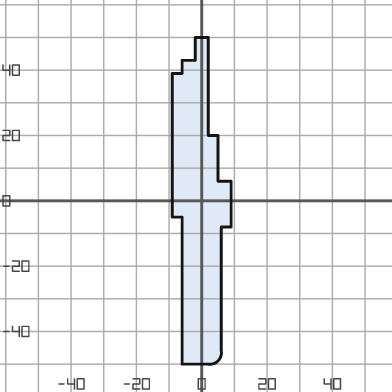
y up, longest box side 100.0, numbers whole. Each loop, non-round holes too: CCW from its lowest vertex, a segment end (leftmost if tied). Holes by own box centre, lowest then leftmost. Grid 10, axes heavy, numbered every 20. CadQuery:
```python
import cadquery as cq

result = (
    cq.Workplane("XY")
    .moveTo(-6.0, -50.0)
    .lineTo(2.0, -50.0)
    .threePointArc((5.0, -49.0), (6.0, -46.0))
    .lineTo(6.0, -8.0)
    .lineTo(9.0, -8.0)
    .lineTo(9.0, 6.0)
    .lineTo(5.0, 6.0)
    .lineTo(5.0, 20.0)
    .lineTo(2.0, 20.0)
    .lineTo(2.0, 50.0)
    .lineTo(-2.0, 50.0)
    .lineTo(-2.0, 43.0)
    .lineTo(-6.0, 43.0)
    .lineTo(-6.0, 39.0)
    .lineTo(-9.0, 39.0)
    .lineTo(-9.0, -5.0)
    .lineTo(-6.0, -5.0)
    .close()
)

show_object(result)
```